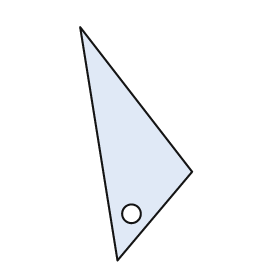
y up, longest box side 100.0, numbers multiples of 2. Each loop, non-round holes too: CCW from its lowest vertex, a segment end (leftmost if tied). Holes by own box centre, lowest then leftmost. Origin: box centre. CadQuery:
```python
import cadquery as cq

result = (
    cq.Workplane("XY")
    .moveTo(-8.0, -50.0)
    .lineTo(24.0, -12.0)
    .lineTo(-24.0, 50.0)
    .close()
    .moveTo(-2.0, -30.0)
    .circle(4.0)
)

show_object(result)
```